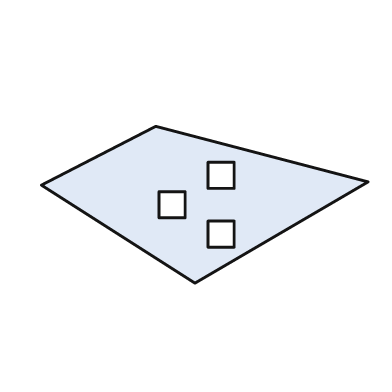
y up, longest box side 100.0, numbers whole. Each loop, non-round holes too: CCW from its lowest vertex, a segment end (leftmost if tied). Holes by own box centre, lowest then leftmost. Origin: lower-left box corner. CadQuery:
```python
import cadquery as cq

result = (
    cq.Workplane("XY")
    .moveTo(47.0, 0.0)
    .lineTo(100.0, 31.0)
    .lineTo(35.0, 48.0)
    .lineTo(0.0, 30.0)
    .close()
    .moveTo(51.0, 11.0)
    .lineTo(59.0, 11.0)
    .lineTo(59.0, 19.0)
    .lineTo(51.0, 19.0)
    .close()
    .moveTo(36.0, 20.0)
    .lineTo(44.0, 20.0)
    .lineTo(44.0, 28.0)
    .lineTo(36.0, 28.0)
    .close()
    .moveTo(51.0, 29.0)
    .lineTo(59.0, 29.0)
    .lineTo(59.0, 37.0)
    .lineTo(51.0, 37.0)
    .close()
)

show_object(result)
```